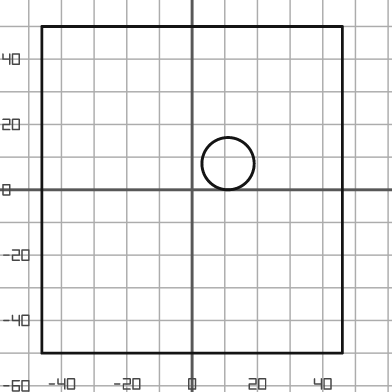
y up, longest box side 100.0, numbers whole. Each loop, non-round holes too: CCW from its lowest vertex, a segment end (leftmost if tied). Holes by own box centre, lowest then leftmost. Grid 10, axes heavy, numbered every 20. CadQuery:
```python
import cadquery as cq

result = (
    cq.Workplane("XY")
    .moveTo(-46.0, -50.0)
    .lineTo(46.0, -50.0)
    .lineTo(46.0, 50.0)
    .lineTo(-46.0, 50.0)
    .close()
    .moveTo(11.0, 8.0)
    .circle(8.0)
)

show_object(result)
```